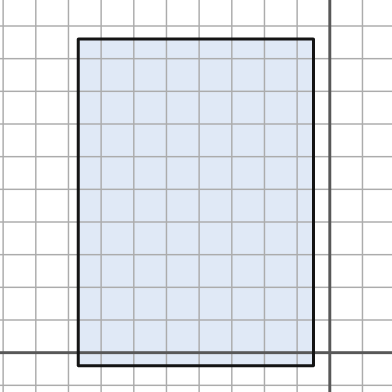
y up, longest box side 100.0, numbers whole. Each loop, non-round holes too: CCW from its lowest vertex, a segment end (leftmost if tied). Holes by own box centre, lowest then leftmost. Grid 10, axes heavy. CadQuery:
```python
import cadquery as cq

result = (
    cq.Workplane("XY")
    .moveTo(-77.0, -4.0)
    .lineTo(-5.0, -4.0)
    .lineTo(-5.0, 96.0)
    .lineTo(-77.0, 96.0)
    .close()
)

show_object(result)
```